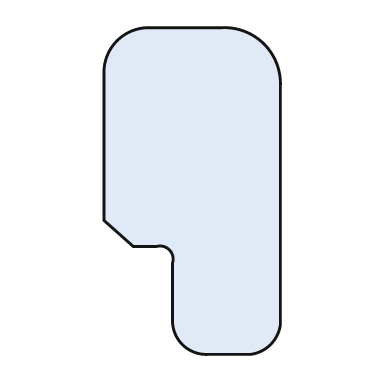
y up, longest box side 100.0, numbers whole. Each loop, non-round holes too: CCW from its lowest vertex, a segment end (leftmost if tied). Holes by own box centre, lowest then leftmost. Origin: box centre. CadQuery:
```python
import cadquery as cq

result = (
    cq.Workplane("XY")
    .moveTo(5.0, -50.0)
    .lineTo(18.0, -50.0)
    .threePointArc((24.0, -47.0), (27.0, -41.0))
    .lineTo(27.0, 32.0)
    .threePointArc((22.0, 45.0), (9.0, 50.0))
    .lineTo(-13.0, 50.0)
    .threePointArc((-23.0, 46.0), (-27.0, 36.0))
    .lineTo(-27.0, -9.0)
    .lineTo(-18.0, -17.0)
    .lineTo(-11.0, -17.0)
    .threePointArc((-7.0, -18.0), (-6.0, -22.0))
    .lineTo(-6.0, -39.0)
    .threePointArc((-3.0, -47.0), (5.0, -50.0))
    .close()
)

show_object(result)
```